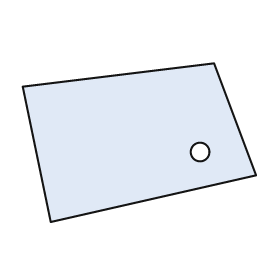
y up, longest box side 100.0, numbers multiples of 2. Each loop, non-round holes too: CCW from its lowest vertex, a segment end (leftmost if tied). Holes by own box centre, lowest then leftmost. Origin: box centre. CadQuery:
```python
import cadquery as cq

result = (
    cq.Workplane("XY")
    .moveTo(-38.0, -34.0)
    .lineTo(50.0, -14.0)
    .lineTo(32.0, 34.0)
    .lineTo(-50.0, 24.0)
    .close()
    .moveTo(26.0, -4.0)
    .circle(4.0)
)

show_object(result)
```